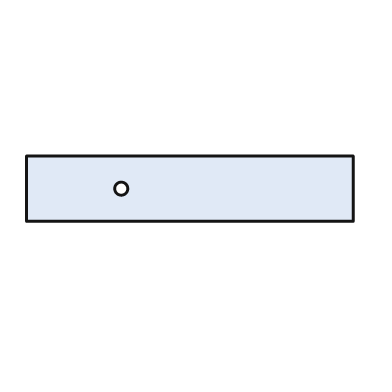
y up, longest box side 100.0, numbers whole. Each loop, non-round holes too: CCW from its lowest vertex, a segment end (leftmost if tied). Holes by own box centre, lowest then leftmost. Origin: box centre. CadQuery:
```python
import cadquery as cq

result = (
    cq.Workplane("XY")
    .moveTo(-50.0, -10.0)
    .lineTo(50.0, -10.0)
    .lineTo(50.0, 10.0)
    .lineTo(-50.0, 10.0)
    .close()
    .moveTo(-21.0, 0.0)
    .circle(2.0)
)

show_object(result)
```